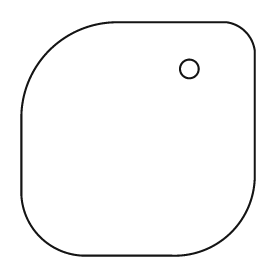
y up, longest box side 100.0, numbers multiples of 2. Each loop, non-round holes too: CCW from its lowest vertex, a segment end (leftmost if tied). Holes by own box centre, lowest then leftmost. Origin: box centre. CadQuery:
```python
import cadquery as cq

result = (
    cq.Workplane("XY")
    .moveTo(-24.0, -50.0)
    .lineTo(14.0, -50.0)
    .threePointArc((40.0, -40.0), (50.0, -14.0))
    .lineTo(50.0, 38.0)
    .threePointArc((46.0, 46.0), (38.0, 50.0))
    .lineTo(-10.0, 50.0)
    .threePointArc((-38.0, 38.0), (-50.0, 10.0))
    .lineTo(-50.0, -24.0)
    .threePointArc((-42.0, -42.0), (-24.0, -50.0))
    .close()
    .moveTo(22.0, 30.0)
    .circle(4.0)
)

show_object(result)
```